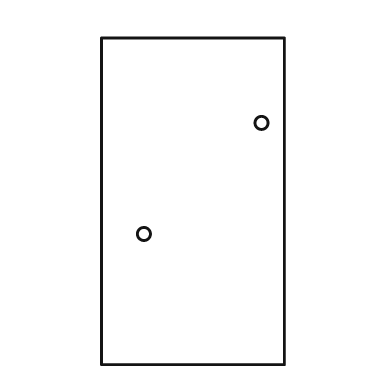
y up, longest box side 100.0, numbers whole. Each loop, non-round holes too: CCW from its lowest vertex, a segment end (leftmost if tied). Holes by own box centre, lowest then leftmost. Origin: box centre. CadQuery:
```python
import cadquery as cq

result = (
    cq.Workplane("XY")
    .moveTo(-28.0, -50.0)
    .lineTo(28.0, -50.0)
    .lineTo(28.0, 50.0)
    .lineTo(-28.0, 50.0)
    .close()
    .moveTo(-15.0, -10.0)
    .circle(2.0)
    .moveTo(21.0, 24.0)
    .circle(2.0)
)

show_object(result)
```